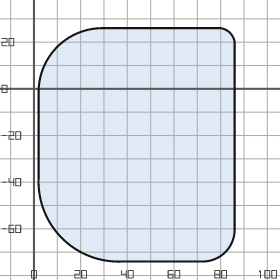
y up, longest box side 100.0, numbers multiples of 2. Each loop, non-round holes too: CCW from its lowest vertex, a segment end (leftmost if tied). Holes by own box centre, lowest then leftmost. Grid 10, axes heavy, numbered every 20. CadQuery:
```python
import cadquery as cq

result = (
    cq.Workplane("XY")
    .moveTo(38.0, -74.0)
    .lineTo(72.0, -74.0)
    .threePointArc((82.0, -70.0), (86.0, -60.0))
    .lineTo(86.0, 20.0)
    .threePointArc((84.0, 24.0), (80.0, 26.0))
    .lineTo(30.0, 26.0)
    .threePointArc((10.0, 18.0), (2.0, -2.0))
    .lineTo(2.0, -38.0)
    .threePointArc((12.0, -64.0), (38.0, -74.0))
    .close()
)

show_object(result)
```